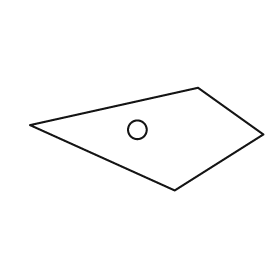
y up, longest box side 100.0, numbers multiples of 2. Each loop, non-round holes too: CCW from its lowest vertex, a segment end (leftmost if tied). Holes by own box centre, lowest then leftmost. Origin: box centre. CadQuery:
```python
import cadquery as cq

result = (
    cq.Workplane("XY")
    .moveTo(12.0, -22.0)
    .lineTo(50.0, 2.0)
    .lineTo(22.0, 22.0)
    .lineTo(-50.0, 6.0)
    .close()
    .moveTo(-4.0, 4.0)
    .circle(4.0)
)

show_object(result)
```